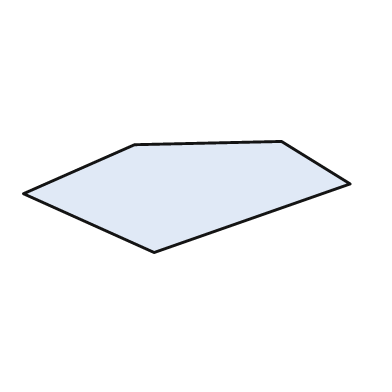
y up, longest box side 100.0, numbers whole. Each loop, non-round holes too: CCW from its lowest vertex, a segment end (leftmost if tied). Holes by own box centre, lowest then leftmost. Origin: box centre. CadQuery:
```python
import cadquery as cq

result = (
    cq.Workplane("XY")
    .moveTo(-10.0, -17.0)
    .lineTo(50.0, 4.0)
    .lineTo(29.0, 17.0)
    .lineTo(-16.0, 16.0)
    .lineTo(-50.0, 1.0)
    .close()
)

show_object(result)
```